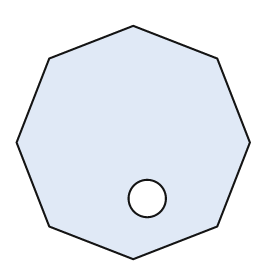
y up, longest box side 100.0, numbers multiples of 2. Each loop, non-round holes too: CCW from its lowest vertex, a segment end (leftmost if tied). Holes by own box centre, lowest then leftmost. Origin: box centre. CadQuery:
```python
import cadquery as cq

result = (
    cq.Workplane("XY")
    .moveTo(0.0, -50.0)
    .lineTo(36.0, -36.0)
    .lineTo(50.0, 0.0)
    .lineTo(36.0, 36.0)
    .lineTo(0.0, 50.0)
    .lineTo(-36.0, 36.0)
    .lineTo(-50.0, 0.0)
    .lineTo(-36.0, -36.0)
    .close()
    .moveTo(6.0, -24.0)
    .circle(8.0)
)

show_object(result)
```